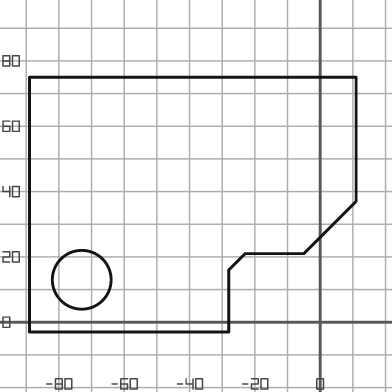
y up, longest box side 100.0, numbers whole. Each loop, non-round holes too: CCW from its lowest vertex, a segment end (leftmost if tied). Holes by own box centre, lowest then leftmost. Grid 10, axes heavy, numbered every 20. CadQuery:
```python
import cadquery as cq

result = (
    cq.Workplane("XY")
    .moveTo(-89.0, -3.0)
    .lineTo(-28.0, -3.0)
    .lineTo(-28.0, 16.0)
    .lineTo(-23.0, 21.0)
    .lineTo(-5.0, 21.0)
    .lineTo(11.0, 37.0)
    .lineTo(11.0, 75.0)
    .lineTo(-89.0, 75.0)
    .close()
    .moveTo(-73.0, 13.0)
    .circle(9.0)
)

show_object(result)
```